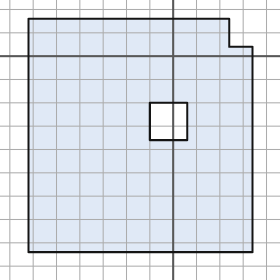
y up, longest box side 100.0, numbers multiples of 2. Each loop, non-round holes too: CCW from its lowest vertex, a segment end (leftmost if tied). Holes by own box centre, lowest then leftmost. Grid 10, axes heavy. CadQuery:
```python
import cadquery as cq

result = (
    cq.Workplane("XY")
    .moveTo(-62.0, -84.0)
    .lineTo(34.0, -84.0)
    .lineTo(34.0, 4.0)
    .lineTo(24.0, 4.0)
    .lineTo(24.0, 16.0)
    .lineTo(-62.0, 16.0)
    .close()
    .moveTo(-10.0, -36.0)
    .lineTo(6.0, -36.0)
    .lineTo(6.0, -20.0)
    .lineTo(-10.0, -20.0)
    .close()
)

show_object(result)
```